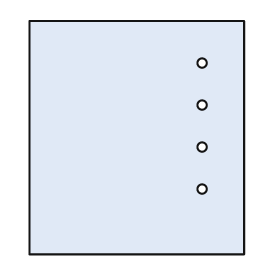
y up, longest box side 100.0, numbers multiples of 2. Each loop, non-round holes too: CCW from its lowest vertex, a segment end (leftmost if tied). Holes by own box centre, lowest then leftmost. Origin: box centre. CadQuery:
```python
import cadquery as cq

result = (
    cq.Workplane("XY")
    .moveTo(-46.0, -50.0)
    .lineTo(46.0, -50.0)
    .lineTo(46.0, 50.0)
    .lineTo(-46.0, 50.0)
    .close()
    .moveTo(28.0, -22.0)
    .circle(2.0)
    .moveTo(28.0, -4.0)
    .circle(2.0)
    .moveTo(28.0, 14.0)
    .circle(2.0)
    .moveTo(28.0, 32.0)
    .circle(2.0)
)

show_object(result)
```